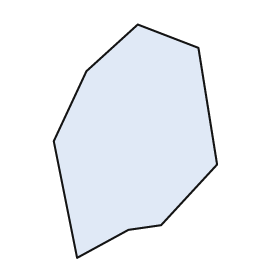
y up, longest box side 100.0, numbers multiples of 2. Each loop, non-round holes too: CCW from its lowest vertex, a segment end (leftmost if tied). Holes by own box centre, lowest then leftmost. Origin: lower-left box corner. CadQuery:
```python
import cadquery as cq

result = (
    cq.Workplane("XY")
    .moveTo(10.0, 0.0)
    .lineTo(32.0, 12.0)
    .lineTo(46.0, 14.0)
    .lineTo(70.0, 40.0)
    .lineTo(62.0, 90.0)
    .lineTo(36.0, 100.0)
    .lineTo(14.0, 80.0)
    .lineTo(0.0, 50.0)
    .close()
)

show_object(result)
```